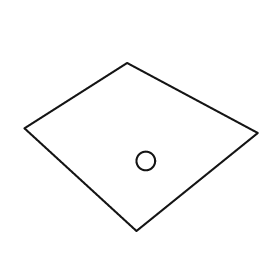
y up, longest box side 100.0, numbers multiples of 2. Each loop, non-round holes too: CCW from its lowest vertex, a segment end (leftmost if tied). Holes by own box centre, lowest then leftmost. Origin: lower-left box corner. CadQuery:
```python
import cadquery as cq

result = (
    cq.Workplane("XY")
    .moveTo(48.0, 0.0)
    .lineTo(100.0, 42.0)
    .lineTo(44.0, 72.0)
    .lineTo(0.0, 44.0)
    .close()
    .moveTo(52.0, 30.0)
    .circle(4.0)
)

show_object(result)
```